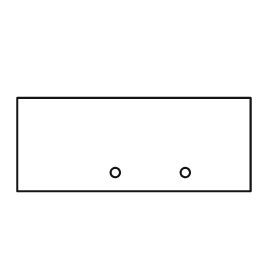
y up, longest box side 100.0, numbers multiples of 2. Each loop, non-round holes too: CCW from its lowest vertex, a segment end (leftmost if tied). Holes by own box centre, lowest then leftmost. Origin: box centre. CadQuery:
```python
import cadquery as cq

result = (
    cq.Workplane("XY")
    .moveTo(-50.0, -20.0)
    .lineTo(50.0, -20.0)
    .lineTo(50.0, 20.0)
    .lineTo(-50.0, 20.0)
    .close()
    .moveTo(-8.0, -12.0)
    .circle(2.0)
    .moveTo(22.0, -12.0)
    .circle(2.0)
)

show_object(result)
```